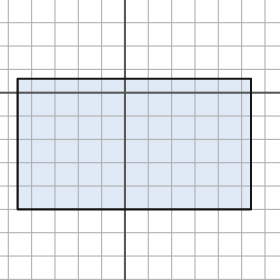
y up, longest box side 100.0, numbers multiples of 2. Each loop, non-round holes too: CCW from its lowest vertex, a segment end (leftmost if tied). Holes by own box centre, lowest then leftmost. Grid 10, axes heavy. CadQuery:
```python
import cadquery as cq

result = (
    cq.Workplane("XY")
    .moveTo(-46.0, -50.0)
    .lineTo(54.0, -50.0)
    .lineTo(54.0, 6.0)
    .lineTo(-46.0, 6.0)
    .close()
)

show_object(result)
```